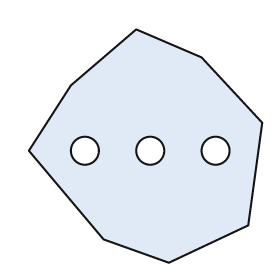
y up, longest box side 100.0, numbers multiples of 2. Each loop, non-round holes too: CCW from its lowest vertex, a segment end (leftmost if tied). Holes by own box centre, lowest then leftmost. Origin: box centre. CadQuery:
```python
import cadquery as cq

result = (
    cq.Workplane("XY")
    .moveTo(10.0, -50.0)
    .lineTo(44.0, -34.0)
    .lineTo(50.0, 10.0)
    .lineTo(24.0, 38.0)
    .lineTo(-4.0, 50.0)
    .lineTo(-32.0, 26.0)
    .lineTo(-50.0, -2.0)
    .lineTo(-18.0, -40.0)
    .close()
    .moveTo(-26.0, -2.0)
    .circle(6.0)
    .moveTo(2.0, -2.0)
    .circle(6.0)
    .moveTo(30.0, -2.0)
    .circle(6.0)
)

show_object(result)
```